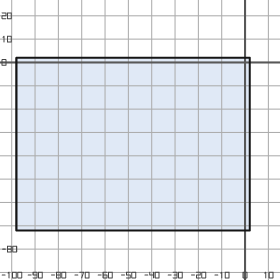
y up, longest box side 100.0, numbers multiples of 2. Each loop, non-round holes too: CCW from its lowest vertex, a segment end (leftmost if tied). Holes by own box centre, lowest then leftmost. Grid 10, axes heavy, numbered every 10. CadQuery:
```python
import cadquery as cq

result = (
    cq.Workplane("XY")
    .moveTo(-98.0, -72.0)
    .lineTo(2.0, -72.0)
    .lineTo(2.0, 2.0)
    .lineTo(-98.0, 2.0)
    .close()
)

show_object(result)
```